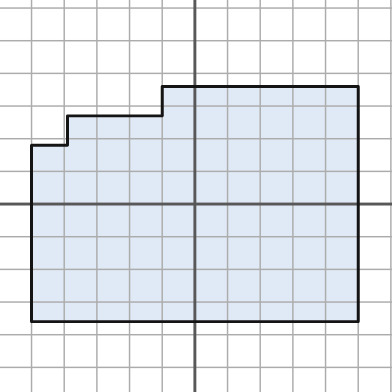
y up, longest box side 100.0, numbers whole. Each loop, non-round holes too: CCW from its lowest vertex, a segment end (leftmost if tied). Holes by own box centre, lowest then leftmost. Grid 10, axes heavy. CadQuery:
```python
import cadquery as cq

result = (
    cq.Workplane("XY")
    .moveTo(-50.0, -36.0)
    .lineTo(50.0, -36.0)
    .lineTo(50.0, 36.0)
    .lineTo(-10.0, 36.0)
    .lineTo(-10.0, 27.0)
    .lineTo(-39.0, 27.0)
    .lineTo(-39.0, 18.0)
    .lineTo(-50.0, 18.0)
    .close()
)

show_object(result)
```